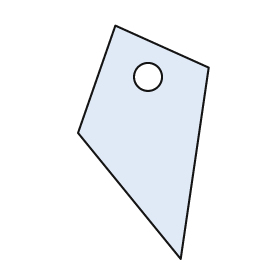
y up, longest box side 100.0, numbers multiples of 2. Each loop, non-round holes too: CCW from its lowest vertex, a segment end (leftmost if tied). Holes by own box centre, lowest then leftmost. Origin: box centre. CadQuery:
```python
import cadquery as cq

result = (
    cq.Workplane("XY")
    .moveTo(16.0, -50.0)
    .lineTo(28.0, 32.0)
    .lineTo(-12.0, 50.0)
    .lineTo(-28.0, 4.0)
    .close()
    .moveTo(2.0, 28.0)
    .circle(6.0)
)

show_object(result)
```